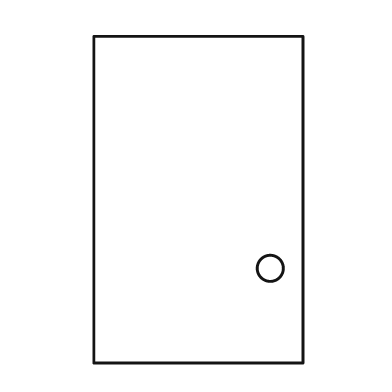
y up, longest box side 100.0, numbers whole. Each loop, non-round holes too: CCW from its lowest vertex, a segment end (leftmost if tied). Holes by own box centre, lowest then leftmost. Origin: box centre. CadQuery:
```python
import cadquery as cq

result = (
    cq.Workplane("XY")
    .moveTo(-32.0, -50.0)
    .lineTo(32.0, -50.0)
    .lineTo(32.0, 50.0)
    .lineTo(-32.0, 50.0)
    .close()
    .moveTo(22.0, -21.0)
    .circle(4.0)
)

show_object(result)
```